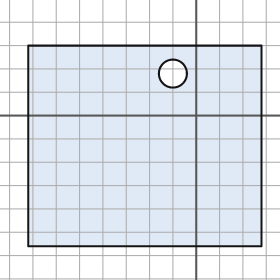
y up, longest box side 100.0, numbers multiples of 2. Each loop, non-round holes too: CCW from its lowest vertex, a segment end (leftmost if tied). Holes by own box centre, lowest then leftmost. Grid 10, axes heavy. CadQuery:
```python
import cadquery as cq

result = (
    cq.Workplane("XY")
    .moveTo(-72.0, -56.0)
    .lineTo(28.0, -56.0)
    .lineTo(28.0, 30.0)
    .lineTo(-72.0, 30.0)
    .close()
    .moveTo(-10.0, 18.0)
    .circle(6.0)
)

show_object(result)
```